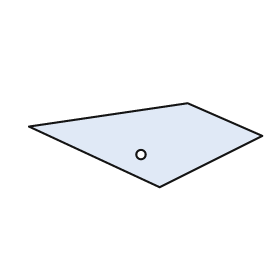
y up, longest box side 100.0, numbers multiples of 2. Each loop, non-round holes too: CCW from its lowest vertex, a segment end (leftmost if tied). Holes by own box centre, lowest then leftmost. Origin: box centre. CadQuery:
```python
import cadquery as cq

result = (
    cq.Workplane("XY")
    .moveTo(6.0, -18.0)
    .lineTo(50.0, 4.0)
    .lineTo(18.0, 18.0)
    .lineTo(-50.0, 8.0)
    .close()
    .moveTo(-2.0, -4.0)
    .circle(2.0)
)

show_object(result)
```